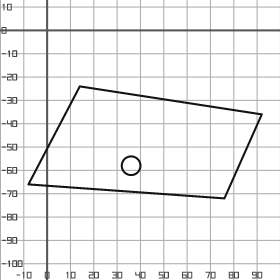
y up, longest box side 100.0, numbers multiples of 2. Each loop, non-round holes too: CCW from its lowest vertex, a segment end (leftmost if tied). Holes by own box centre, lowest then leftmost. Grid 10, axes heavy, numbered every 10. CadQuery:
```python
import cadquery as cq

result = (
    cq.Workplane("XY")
    .moveTo(76.0, -72.0)
    .lineTo(92.0, -36.0)
    .lineTo(14.0, -24.0)
    .lineTo(-8.0, -66.0)
    .close()
    .moveTo(36.0, -58.0)
    .circle(4.0)
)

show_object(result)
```